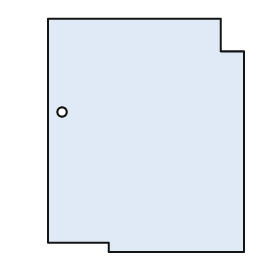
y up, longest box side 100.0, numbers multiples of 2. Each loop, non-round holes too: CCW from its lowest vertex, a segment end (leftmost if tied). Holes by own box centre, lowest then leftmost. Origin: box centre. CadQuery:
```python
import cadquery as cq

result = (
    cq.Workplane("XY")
    .moveTo(-16.0, -50.0)
    .lineTo(42.0, -50.0)
    .lineTo(42.0, 36.0)
    .lineTo(32.0, 36.0)
    .lineTo(32.0, 50.0)
    .lineTo(-42.0, 50.0)
    .lineTo(-42.0, -46.0)
    .lineTo(-16.0, -46.0)
    .close()
    .moveTo(-36.0, 10.0)
    .circle(2.0)
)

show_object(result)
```